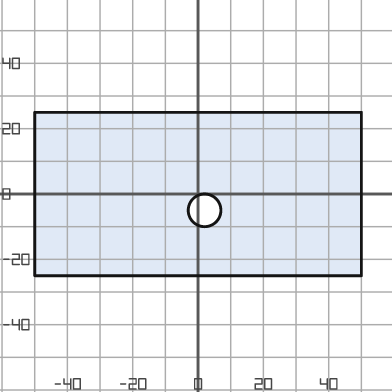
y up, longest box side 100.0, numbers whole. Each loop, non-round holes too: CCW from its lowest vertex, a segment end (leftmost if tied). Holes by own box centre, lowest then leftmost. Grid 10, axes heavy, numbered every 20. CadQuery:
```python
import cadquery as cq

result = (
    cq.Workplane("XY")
    .moveTo(-50.0, -25.0)
    .lineTo(50.0, -25.0)
    .lineTo(50.0, 25.0)
    .lineTo(-50.0, 25.0)
    .close()
    .moveTo(2.0, -5.0)
    .circle(5.0)
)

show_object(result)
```